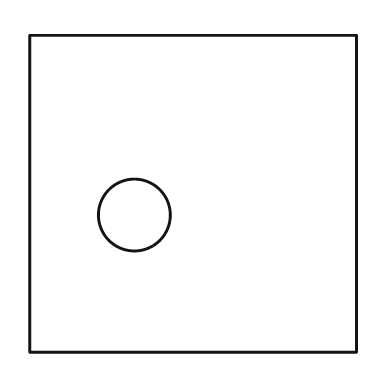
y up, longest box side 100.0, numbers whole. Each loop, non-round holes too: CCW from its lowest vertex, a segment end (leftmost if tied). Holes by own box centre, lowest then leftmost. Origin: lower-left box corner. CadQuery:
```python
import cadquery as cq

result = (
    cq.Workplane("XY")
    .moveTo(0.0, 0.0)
    .lineTo(100.0, 0.0)
    .lineTo(100.0, 97.0)
    .lineTo(0.0, 97.0)
    .close()
    .moveTo(32.0, 42.0)
    .circle(11.0)
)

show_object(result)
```